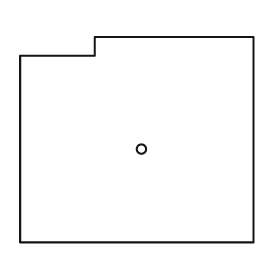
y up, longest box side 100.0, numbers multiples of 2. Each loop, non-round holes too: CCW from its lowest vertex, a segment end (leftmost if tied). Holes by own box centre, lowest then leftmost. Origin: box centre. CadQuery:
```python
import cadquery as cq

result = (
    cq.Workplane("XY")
    .moveTo(-50.0, -44.0)
    .lineTo(50.0, -44.0)
    .lineTo(50.0, 44.0)
    .lineTo(-18.0, 44.0)
    .lineTo(-18.0, 36.0)
    .lineTo(-50.0, 36.0)
    .close()
    .moveTo(2.0, -4.0)
    .circle(2.0)
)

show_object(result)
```